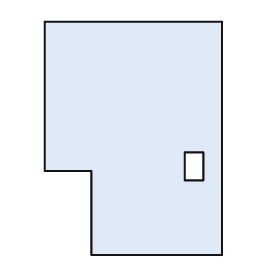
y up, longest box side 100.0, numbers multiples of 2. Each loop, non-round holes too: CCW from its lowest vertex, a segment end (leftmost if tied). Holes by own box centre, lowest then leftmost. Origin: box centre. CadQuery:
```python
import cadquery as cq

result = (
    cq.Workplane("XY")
    .moveTo(-18.0, -50.0)
    .lineTo(38.0, -50.0)
    .lineTo(38.0, 50.0)
    .lineTo(-38.0, 50.0)
    .lineTo(-38.0, -14.0)
    .lineTo(-18.0, -14.0)
    .close()
    .moveTo(22.0, -18.0)
    .lineTo(30.0, -18.0)
    .lineTo(30.0, -6.0)
    .lineTo(22.0, -6.0)
    .close()
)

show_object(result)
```